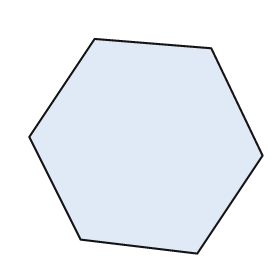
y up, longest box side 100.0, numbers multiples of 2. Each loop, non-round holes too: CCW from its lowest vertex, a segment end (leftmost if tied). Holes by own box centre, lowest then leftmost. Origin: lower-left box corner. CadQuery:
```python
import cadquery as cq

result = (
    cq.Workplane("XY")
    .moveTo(72.0, 0.0)
    .lineTo(100.0, 42.0)
    .lineTo(78.0, 88.0)
    .lineTo(28.0, 92.0)
    .lineTo(0.0, 50.0)
    .lineTo(22.0, 6.0)
    .close()
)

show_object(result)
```